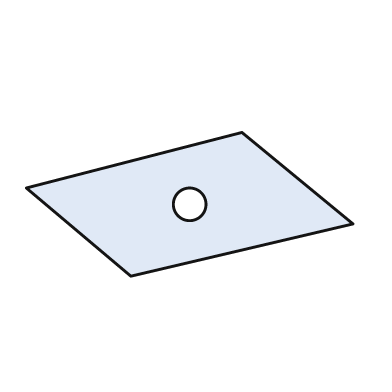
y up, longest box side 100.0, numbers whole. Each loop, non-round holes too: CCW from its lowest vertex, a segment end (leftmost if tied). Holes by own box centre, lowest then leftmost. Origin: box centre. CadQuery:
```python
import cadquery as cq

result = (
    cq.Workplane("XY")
    .moveTo(-18.0, -22.0)
    .lineTo(50.0, -6.0)
    .lineTo(16.0, 22.0)
    .lineTo(-50.0, 5.0)
    .close()
    .moveTo(0.0, 0.0)
    .circle(5.0)
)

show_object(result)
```